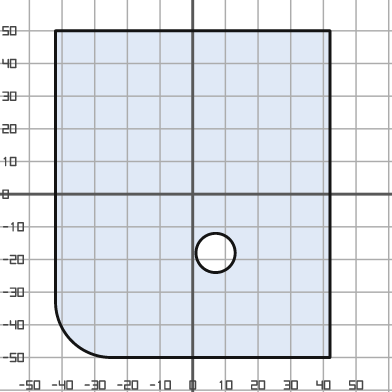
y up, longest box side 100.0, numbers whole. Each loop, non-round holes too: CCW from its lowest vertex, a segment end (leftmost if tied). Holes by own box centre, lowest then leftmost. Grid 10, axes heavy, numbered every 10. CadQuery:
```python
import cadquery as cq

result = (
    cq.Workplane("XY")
    .moveTo(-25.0, -50.0)
    .lineTo(42.0, -50.0)
    .lineTo(42.0, 50.0)
    .lineTo(-42.0, 50.0)
    .lineTo(-42.0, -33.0)
    .threePointArc((-37.0, -45.0), (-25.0, -50.0))
    .close()
    .moveTo(7.0, -18.0)
    .circle(6.0)
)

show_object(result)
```